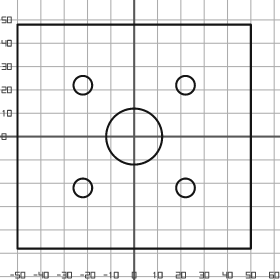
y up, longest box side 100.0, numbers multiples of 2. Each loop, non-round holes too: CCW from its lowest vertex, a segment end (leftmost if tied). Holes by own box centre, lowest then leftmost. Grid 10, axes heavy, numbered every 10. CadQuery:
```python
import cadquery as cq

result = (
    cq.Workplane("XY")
    .moveTo(-50.0, -48.0)
    .lineTo(50.0, -48.0)
    .lineTo(50.0, 48.0)
    .lineTo(-50.0, 48.0)
    .close()
    .moveTo(-22.0, -22.0)
    .circle(4.0)
    .moveTo(22.0, -22.0)
    .circle(4.0)
    .moveTo(0.0, 0.0)
    .circle(12.0)
    .moveTo(-22.0, 22.0)
    .circle(4.0)
    .moveTo(22.0, 22.0)
    .circle(4.0)
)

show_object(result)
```